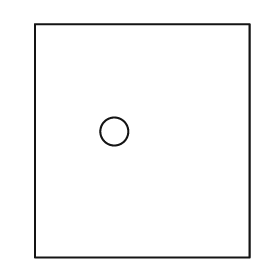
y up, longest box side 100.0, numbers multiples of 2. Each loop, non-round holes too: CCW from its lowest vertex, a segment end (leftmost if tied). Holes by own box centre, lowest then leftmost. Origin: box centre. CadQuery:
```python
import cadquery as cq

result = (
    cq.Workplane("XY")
    .moveTo(-46.0, -50.0)
    .lineTo(46.0, -50.0)
    .lineTo(46.0, 50.0)
    .lineTo(-46.0, 50.0)
    .close()
    .moveTo(-12.0, 4.0)
    .circle(6.0)
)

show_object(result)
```